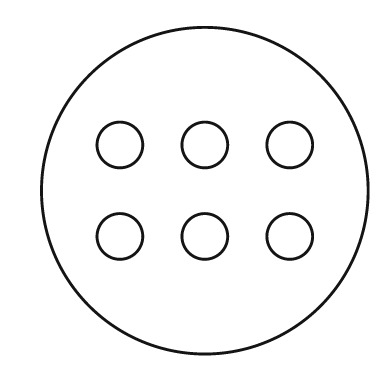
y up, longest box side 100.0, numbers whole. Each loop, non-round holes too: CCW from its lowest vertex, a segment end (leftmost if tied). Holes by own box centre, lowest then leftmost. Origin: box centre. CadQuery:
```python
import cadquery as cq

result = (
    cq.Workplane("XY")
    .moveTo(0.0, 0.0)
    .circle(50.0)
    .moveTo(-26.0, -14.0)
    .circle(7.0)
    .moveTo(0.0, -14.0)
    .circle(7.0)
    .moveTo(26.0, -14.0)
    .circle(7.0)
    .moveTo(-26.0, 14.0)
    .circle(7.0)
    .moveTo(0.0, 14.0)
    .circle(7.0)
    .moveTo(26.0, 14.0)
    .circle(7.0)
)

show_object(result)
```